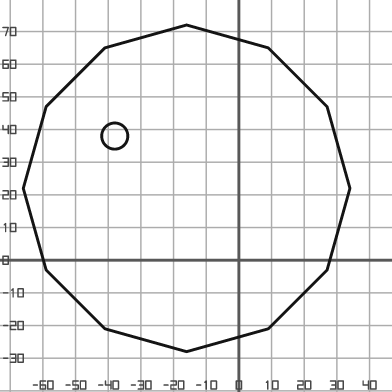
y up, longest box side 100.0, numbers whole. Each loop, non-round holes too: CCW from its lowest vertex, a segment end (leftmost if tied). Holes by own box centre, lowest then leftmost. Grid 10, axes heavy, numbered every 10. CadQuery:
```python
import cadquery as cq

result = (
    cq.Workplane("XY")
    .moveTo(-16.0, -28.0)
    .lineTo(9.0, -21.0)
    .lineTo(27.0, -3.0)
    .lineTo(34.0, 22.0)
    .lineTo(27.0, 47.0)
    .lineTo(9.0, 65.0)
    .lineTo(-16.0, 72.0)
    .lineTo(-41.0, 65.0)
    .lineTo(-59.0, 47.0)
    .lineTo(-66.0, 22.0)
    .lineTo(-59.0, -3.0)
    .lineTo(-41.0, -21.0)
    .close()
    .moveTo(-38.0, 38.0)
    .circle(4.0)
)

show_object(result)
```